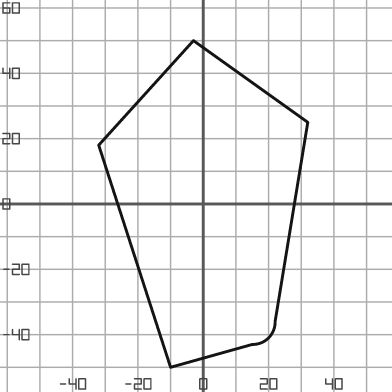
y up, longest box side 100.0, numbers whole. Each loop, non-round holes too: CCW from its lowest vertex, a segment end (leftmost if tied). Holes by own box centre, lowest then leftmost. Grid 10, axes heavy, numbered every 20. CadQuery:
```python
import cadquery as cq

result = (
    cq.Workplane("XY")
    .moveTo(-10.0, -50.0)
    .lineTo(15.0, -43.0)
    .threePointArc((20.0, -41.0), (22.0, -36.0))
    .lineTo(32.0, 25.0)
    .lineTo(-3.0, 50.0)
    .lineTo(-32.0, 18.0)
    .close()
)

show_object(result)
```